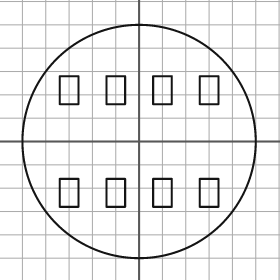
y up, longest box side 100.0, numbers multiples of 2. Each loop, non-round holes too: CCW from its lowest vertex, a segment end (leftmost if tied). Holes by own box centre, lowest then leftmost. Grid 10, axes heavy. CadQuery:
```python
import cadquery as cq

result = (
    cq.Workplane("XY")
    .moveTo(0.0, 0.0)
    .circle(50.0)
    .moveTo(-34.0, -28.0)
    .lineTo(-26.0, -28.0)
    .lineTo(-26.0, -16.0)
    .lineTo(-34.0, -16.0)
    .close()
    .moveTo(-14.0, -28.0)
    .lineTo(-6.0, -28.0)
    .lineTo(-6.0, -16.0)
    .lineTo(-14.0, -16.0)
    .close()
    .moveTo(6.0, -28.0)
    .lineTo(14.0, -28.0)
    .lineTo(14.0, -16.0)
    .lineTo(6.0, -16.0)
    .close()
    .moveTo(26.0, -28.0)
    .lineTo(34.0, -28.0)
    .lineTo(34.0, -16.0)
    .lineTo(26.0, -16.0)
    .close()
    .moveTo(-34.0, 16.0)
    .lineTo(-26.0, 16.0)
    .lineTo(-26.0, 28.0)
    .lineTo(-34.0, 28.0)
    .close()
    .moveTo(-14.0, 16.0)
    .lineTo(-6.0, 16.0)
    .lineTo(-6.0, 28.0)
    .lineTo(-14.0, 28.0)
    .close()
    .moveTo(6.0, 16.0)
    .lineTo(14.0, 16.0)
    .lineTo(14.0, 28.0)
    .lineTo(6.0, 28.0)
    .close()
    .moveTo(26.0, 16.0)
    .lineTo(34.0, 16.0)
    .lineTo(34.0, 28.0)
    .lineTo(26.0, 28.0)
    .close()
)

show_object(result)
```